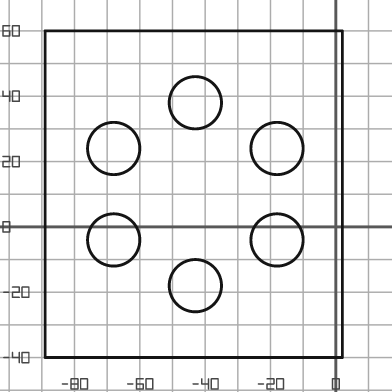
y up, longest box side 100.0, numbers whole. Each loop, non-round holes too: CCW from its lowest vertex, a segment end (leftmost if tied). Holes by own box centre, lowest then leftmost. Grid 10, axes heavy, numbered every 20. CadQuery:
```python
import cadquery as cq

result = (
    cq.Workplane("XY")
    .moveTo(-89.0, -40.0)
    .lineTo(2.0, -40.0)
    .lineTo(2.0, 60.0)
    .lineTo(-89.0, 60.0)
    .close()
    .moveTo(-43.0, -18.0)
    .circle(8.0)
    .moveTo(-68.0, -4.0)
    .circle(8.0)
    .moveTo(-18.0, -4.0)
    .circle(8.0)
    .moveTo(-68.0, 24.0)
    .circle(8.0)
    .moveTo(-18.0, 24.0)
    .circle(8.0)
    .moveTo(-43.0, 38.0)
    .circle(8.0)
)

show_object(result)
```